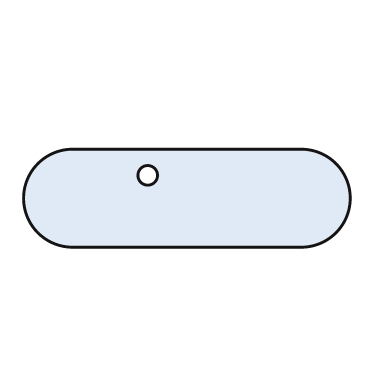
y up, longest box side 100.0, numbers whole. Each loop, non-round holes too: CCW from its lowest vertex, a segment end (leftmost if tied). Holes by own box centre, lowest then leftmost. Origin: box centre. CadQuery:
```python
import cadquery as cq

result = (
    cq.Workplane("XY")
    .moveTo(-35.0, -15.0)
    .lineTo(35.0, -15.0)
    .threePointArc((50.0, 0.0), (35.0, 15.0))
    .lineTo(-35.0, 15.0)
    .threePointArc((-50.0, 0.0), (-35.0, -15.0))
    .close()
    .moveTo(-12.0, 7.0)
    .circle(3.0)
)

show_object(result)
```